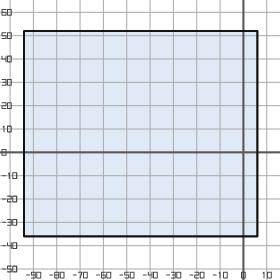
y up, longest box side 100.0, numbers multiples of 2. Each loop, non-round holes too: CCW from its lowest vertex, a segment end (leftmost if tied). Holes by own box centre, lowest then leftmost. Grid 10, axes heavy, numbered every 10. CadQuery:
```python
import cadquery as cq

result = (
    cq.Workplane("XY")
    .moveTo(-94.0, -36.0)
    .lineTo(6.0, -36.0)
    .lineTo(6.0, 52.0)
    .lineTo(-94.0, 52.0)
    .close()
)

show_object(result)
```